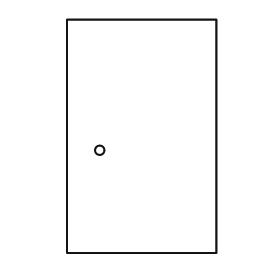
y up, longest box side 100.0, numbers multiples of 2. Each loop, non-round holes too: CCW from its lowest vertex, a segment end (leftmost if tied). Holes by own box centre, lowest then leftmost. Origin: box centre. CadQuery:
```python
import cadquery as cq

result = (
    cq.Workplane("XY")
    .moveTo(-32.0, -50.0)
    .lineTo(32.0, -50.0)
    .lineTo(32.0, 50.0)
    .lineTo(-32.0, 50.0)
    .close()
    .moveTo(-18.0, -6.0)
    .circle(2.0)
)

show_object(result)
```